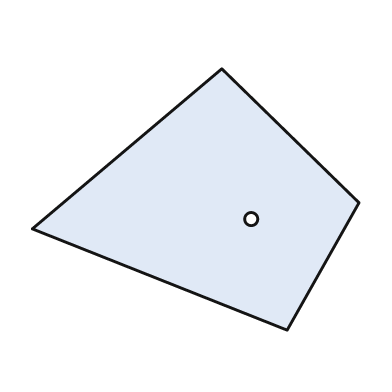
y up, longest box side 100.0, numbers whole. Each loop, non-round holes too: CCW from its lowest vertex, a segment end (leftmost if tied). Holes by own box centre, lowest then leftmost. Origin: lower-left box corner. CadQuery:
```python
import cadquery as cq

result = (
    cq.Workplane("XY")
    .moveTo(78.0, 0.0)
    .lineTo(100.0, 39.0)
    .lineTo(58.0, 80.0)
    .lineTo(0.0, 31.0)
    .close()
    .moveTo(67.0, 34.0)
    .circle(2.0)
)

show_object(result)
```